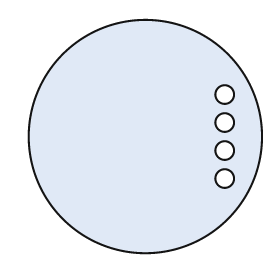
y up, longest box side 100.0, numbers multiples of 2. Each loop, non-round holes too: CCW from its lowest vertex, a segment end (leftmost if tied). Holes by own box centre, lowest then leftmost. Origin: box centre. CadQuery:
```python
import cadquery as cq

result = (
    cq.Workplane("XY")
    .moveTo(0.0, 0.0)
    .circle(50.0)
    .moveTo(34.0, -18.0)
    .circle(4.0)
    .moveTo(34.0, -6.0)
    .circle(4.0)
    .moveTo(34.0, 6.0)
    .circle(4.0)
    .moveTo(34.0, 18.0)
    .circle(4.0)
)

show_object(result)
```